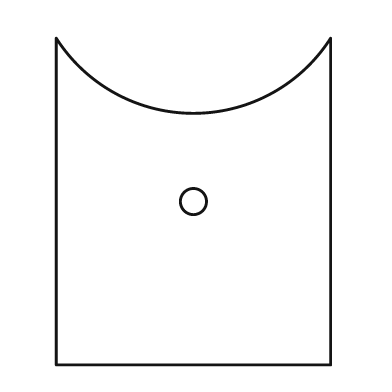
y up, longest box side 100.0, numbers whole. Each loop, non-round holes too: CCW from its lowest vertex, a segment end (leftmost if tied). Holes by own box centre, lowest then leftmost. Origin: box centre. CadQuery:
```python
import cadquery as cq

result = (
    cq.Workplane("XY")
    .moveTo(-42.0, -50.0)
    .lineTo(42.0, -50.0)
    .lineTo(42.0, 50.0)
    .threePointArc((0.0, 27.0), (-42.0, 50.0))
    .close()
    .moveTo(0.0, 0.0)
    .circle(4.0)
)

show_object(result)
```